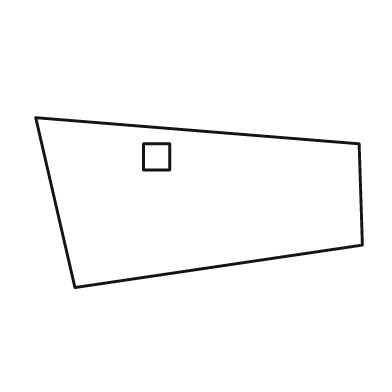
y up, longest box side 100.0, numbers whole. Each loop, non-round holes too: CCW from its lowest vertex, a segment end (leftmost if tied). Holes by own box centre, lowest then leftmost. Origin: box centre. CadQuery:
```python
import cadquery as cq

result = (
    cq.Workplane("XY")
    .moveTo(-38.0, -26.0)
    .lineTo(50.0, -13.0)
    .lineTo(49.0, 18.0)
    .lineTo(-50.0, 26.0)
    .close()
    .moveTo(-17.0, 10.0)
    .lineTo(-9.0, 10.0)
    .lineTo(-9.0, 18.0)
    .lineTo(-17.0, 18.0)
    .close()
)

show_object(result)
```